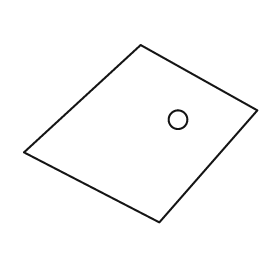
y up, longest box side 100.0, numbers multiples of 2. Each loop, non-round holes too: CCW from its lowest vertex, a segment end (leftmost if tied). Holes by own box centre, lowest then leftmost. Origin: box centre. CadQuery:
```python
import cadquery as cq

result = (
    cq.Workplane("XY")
    .moveTo(8.0, -38.0)
    .lineTo(50.0, 10.0)
    .lineTo(0.0, 38.0)
    .lineTo(-50.0, -8.0)
    .close()
    .moveTo(16.0, 6.0)
    .circle(4.0)
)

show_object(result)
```